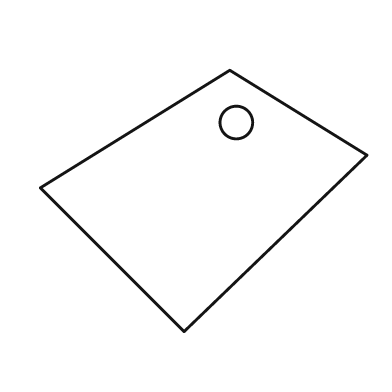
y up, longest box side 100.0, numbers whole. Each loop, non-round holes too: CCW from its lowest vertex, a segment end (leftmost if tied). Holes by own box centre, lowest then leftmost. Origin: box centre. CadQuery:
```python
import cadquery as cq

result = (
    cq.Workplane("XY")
    .moveTo(-6.0, -40.0)
    .lineTo(50.0, 14.0)
    .lineTo(8.0, 40.0)
    .lineTo(-50.0, 4.0)
    .close()
    .moveTo(10.0, 24.0)
    .circle(5.0)
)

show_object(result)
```